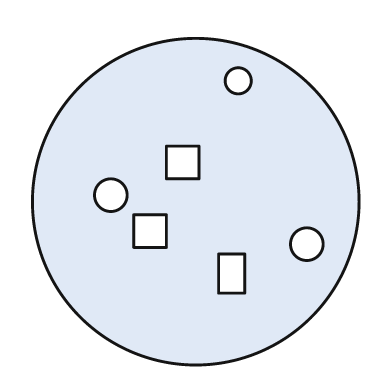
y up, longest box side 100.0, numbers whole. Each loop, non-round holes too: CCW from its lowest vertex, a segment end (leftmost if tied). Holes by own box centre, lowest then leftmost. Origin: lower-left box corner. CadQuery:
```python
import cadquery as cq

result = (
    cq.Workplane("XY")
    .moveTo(50.0, 50.0)
    .circle(50.0)
    .moveTo(57.0, 22.0)
    .lineTo(65.0, 22.0)
    .lineTo(65.0, 34.0)
    .lineTo(57.0, 34.0)
    .close()
    .moveTo(84.0, 37.0)
    .circle(5.0)
    .moveTo(31.0, 36.0)
    .lineTo(41.0, 36.0)
    .lineTo(41.0, 46.0)
    .lineTo(31.0, 46.0)
    .close()
    .moveTo(24.0, 52.0)
    .circle(5.0)
    .moveTo(41.0, 57.0)
    .lineTo(51.0, 57.0)
    .lineTo(51.0, 67.0)
    .lineTo(41.0, 67.0)
    .close()
    .moveTo(63.0, 87.0)
    .circle(4.0)
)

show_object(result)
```